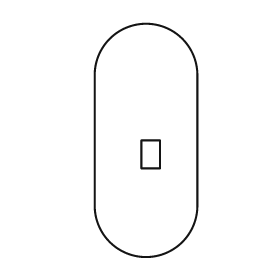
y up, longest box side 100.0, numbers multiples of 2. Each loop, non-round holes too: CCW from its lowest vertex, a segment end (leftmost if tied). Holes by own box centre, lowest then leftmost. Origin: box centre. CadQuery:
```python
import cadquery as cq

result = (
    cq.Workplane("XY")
    .moveTo(-22.0, -28.0)
    .threePointArc((0.0, -50.0), (22.0, -28.0))
    .lineTo(22.0, 28.0)
    .threePointArc((0.0, 50.0), (-22.0, 28.0))
    .close()
    .moveTo(-2.0, -12.0)
    .lineTo(6.0, -12.0)
    .lineTo(6.0, 0.0)
    .lineTo(-2.0, 0.0)
    .close()
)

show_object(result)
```